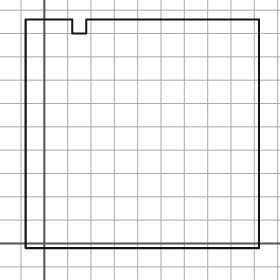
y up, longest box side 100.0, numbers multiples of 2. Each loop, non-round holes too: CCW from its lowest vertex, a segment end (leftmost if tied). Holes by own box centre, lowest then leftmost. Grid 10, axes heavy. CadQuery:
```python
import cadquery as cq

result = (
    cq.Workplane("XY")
    .moveTo(-8.0, -2.0)
    .lineTo(92.0, -2.0)
    .lineTo(92.0, 96.0)
    .lineTo(18.0, 96.0)
    .lineTo(18.0, 90.0)
    .lineTo(12.0, 90.0)
    .lineTo(12.0, 96.0)
    .lineTo(-8.0, 96.0)
    .close()
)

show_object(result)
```